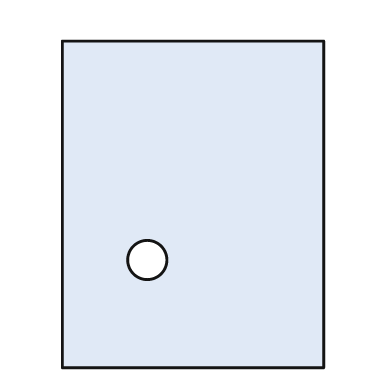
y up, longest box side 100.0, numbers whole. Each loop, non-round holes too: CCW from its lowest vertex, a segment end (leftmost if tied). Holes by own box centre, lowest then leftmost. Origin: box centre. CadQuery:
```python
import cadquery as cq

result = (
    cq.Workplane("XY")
    .moveTo(-40.0, -50.0)
    .lineTo(40.0, -50.0)
    .lineTo(40.0, 50.0)
    .lineTo(-40.0, 50.0)
    .close()
    .moveTo(-14.0, -17.0)
    .circle(6.0)
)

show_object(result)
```